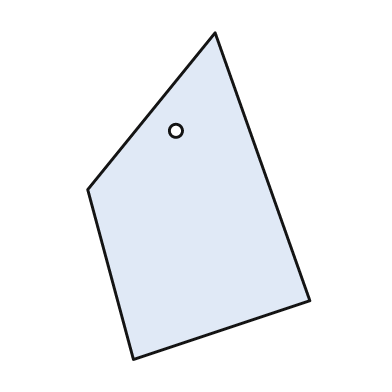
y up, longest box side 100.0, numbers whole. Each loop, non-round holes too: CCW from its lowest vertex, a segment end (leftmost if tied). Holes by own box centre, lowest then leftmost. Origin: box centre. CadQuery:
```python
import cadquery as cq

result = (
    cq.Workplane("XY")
    .moveTo(-20.0, -50.0)
    .lineTo(34.0, -32.0)
    .lineTo(5.0, 50.0)
    .lineTo(-34.0, 2.0)
    .close()
    .moveTo(-7.0, 20.0)
    .circle(2.0)
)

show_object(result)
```